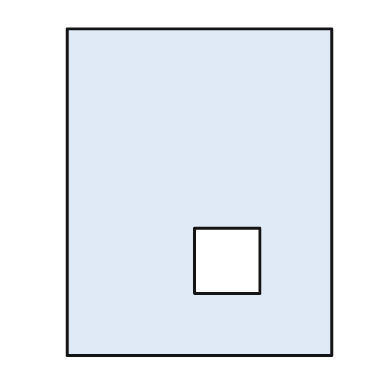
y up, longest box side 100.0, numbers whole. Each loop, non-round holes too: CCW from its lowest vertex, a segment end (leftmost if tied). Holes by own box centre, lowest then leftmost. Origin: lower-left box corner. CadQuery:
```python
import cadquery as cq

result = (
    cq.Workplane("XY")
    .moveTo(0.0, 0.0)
    .lineTo(81.0, 0.0)
    .lineTo(81.0, 100.0)
    .lineTo(0.0, 100.0)
    .close()
    .moveTo(39.0, 19.0)
    .lineTo(59.0, 19.0)
    .lineTo(59.0, 39.0)
    .lineTo(39.0, 39.0)
    .close()
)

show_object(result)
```